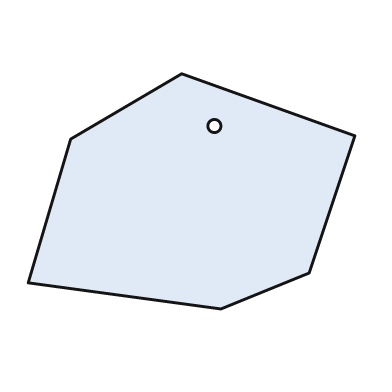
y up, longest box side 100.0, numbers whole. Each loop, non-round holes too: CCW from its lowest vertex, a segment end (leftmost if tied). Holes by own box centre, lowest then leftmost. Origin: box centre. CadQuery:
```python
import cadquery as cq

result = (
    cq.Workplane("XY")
    .moveTo(9.0, -36.0)
    .lineTo(36.0, -25.0)
    .lineTo(50.0, 17.0)
    .lineTo(-3.0, 36.0)
    .lineTo(-37.0, 16.0)
    .lineTo(-50.0, -28.0)
    .close()
    .moveTo(7.0, 20.0)
    .circle(2.0)
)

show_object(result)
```